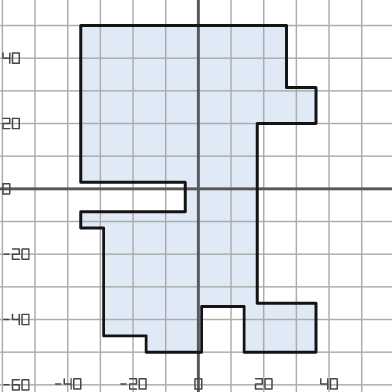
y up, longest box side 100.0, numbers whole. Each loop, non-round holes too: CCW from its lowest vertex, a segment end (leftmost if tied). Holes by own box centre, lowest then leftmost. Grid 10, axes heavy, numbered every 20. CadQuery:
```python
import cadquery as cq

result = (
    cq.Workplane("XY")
    .moveTo(-16.0, -50.0)
    .lineTo(1.0, -50.0)
    .lineTo(1.0, -36.0)
    .lineTo(14.0, -36.0)
    .lineTo(14.0, -50.0)
    .lineTo(36.0, -50.0)
    .lineTo(36.0, -35.0)
    .lineTo(18.0, -35.0)
    .lineTo(18.0, 20.0)
    .lineTo(36.0, 20.0)
    .lineTo(36.0, 31.0)
    .lineTo(27.0, 31.0)
    .lineTo(27.0, 50.0)
    .lineTo(-36.0, 50.0)
    .lineTo(-36.0, 2.0)
    .lineTo(-4.0, 2.0)
    .lineTo(-4.0, -7.0)
    .lineTo(-36.0, -7.0)
    .lineTo(-36.0, -12.0)
    .lineTo(-29.0, -12.0)
    .lineTo(-29.0, -45.0)
    .lineTo(-16.0, -45.0)
    .close()
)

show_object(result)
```